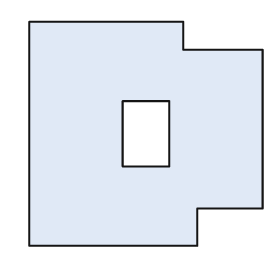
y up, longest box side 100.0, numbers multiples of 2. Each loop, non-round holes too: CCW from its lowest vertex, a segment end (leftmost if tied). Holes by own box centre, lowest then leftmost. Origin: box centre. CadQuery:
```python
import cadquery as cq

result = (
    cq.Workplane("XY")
    .moveTo(-50.0, -48.0)
    .lineTo(22.0, -48.0)
    .lineTo(22.0, -32.0)
    .lineTo(50.0, -32.0)
    .lineTo(50.0, 36.0)
    .lineTo(16.0, 36.0)
    .lineTo(16.0, 48.0)
    .lineTo(-50.0, 48.0)
    .close()
    .moveTo(-10.0, -14.0)
    .lineTo(10.0, -14.0)
    .lineTo(10.0, 14.0)
    .lineTo(-10.0, 14.0)
    .close()
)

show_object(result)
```